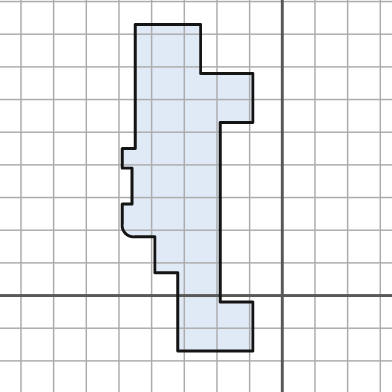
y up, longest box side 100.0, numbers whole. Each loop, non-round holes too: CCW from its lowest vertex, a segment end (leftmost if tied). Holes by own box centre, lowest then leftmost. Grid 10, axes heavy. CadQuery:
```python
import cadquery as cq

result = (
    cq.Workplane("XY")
    .moveTo(-32.0, -17.0)
    .lineTo(-9.0, -17.0)
    .lineTo(-9.0, -2.0)
    .lineTo(-19.0, -2.0)
    .lineTo(-19.0, 53.0)
    .lineTo(-9.0, 53.0)
    .lineTo(-9.0, 68.0)
    .lineTo(-25.0, 68.0)
    .lineTo(-25.0, 83.0)
    .lineTo(-45.0, 83.0)
    .lineTo(-45.0, 45.0)
    .lineTo(-49.0, 45.0)
    .lineTo(-49.0, 39.0)
    .lineTo(-46.0, 39.0)
    .lineTo(-46.0, 28.0)
    .lineTo(-49.0, 28.0)
    .lineTo(-49.0, 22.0)
    .threePointArc((-48.0, 19.0), (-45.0, 18.0))
    .lineTo(-39.0, 18.0)
    .lineTo(-39.0, 7.0)
    .lineTo(-32.0, 7.0)
    .close()
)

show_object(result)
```